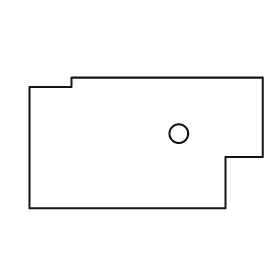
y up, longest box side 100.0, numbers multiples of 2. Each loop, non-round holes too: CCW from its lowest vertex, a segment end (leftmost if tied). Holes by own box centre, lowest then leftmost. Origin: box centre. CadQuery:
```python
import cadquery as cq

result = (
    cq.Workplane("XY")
    .moveTo(-50.0, -28.0)
    .lineTo(34.0, -28.0)
    .lineTo(34.0, -6.0)
    .lineTo(50.0, -6.0)
    .lineTo(50.0, 28.0)
    .lineTo(-32.0, 28.0)
    .lineTo(-32.0, 24.0)
    .lineTo(-50.0, 24.0)
    .close()
    .moveTo(14.0, 4.0)
    .circle(4.0)
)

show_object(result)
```